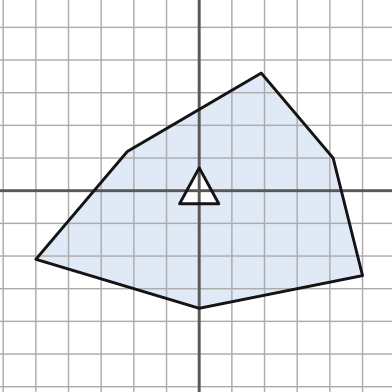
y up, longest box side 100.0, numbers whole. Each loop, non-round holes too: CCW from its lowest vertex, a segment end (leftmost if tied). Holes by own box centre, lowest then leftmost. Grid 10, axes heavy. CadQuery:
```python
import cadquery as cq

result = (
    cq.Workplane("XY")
    .moveTo(0.0, -36.0)
    .lineTo(50.0, -26.0)
    .lineTo(41.0, 10.0)
    .lineTo(19.0, 36.0)
    .lineTo(-22.0, 12.0)
    .lineTo(-50.0, -21.0)
    .close()
    .moveTo(-6.0, -4.0)
    .lineTo(6.0, -4.0)
    .lineTo(0.0, 7.0)
    .close()
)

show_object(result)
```